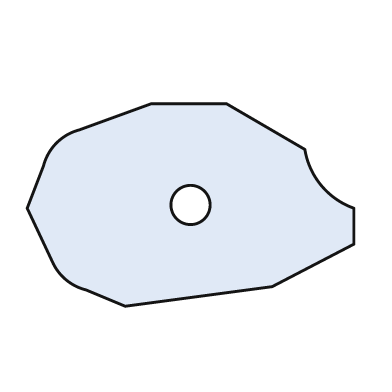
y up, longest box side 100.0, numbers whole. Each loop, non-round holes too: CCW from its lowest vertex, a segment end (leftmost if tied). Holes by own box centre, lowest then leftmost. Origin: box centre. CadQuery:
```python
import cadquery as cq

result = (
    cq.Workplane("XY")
    .moveTo(-20.0, -31.0)
    .lineTo(25.0, -25.0)
    .lineTo(50.0, -12.0)
    .lineTo(50.0, -1.0)
    .threePointArc((40.0, 6.0), (35.0, 17.0))
    .lineTo(11.0, 31.0)
    .lineTo(-12.0, 31.0)
    .lineTo(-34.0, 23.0)
    .threePointArc((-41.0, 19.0), (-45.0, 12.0))
    .lineTo(-50.0, -1.0)
    .lineTo(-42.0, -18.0)
    .threePointArc((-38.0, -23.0), (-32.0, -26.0))
    .close()
    .moveTo(0.0, 0.0)
    .circle(6.0)
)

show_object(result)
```